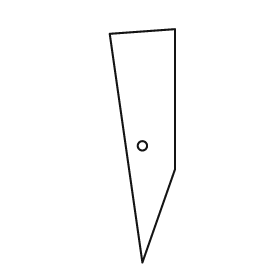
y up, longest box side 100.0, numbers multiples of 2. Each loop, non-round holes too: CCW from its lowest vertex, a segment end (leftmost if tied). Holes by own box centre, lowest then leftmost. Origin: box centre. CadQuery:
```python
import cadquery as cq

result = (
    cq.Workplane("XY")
    .moveTo(0.0, -50.0)
    .lineTo(14.0, -10.0)
    .lineTo(14.0, 50.0)
    .lineTo(-14.0, 48.0)
    .close()
    .moveTo(0.0, 0.0)
    .circle(2.0)
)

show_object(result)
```